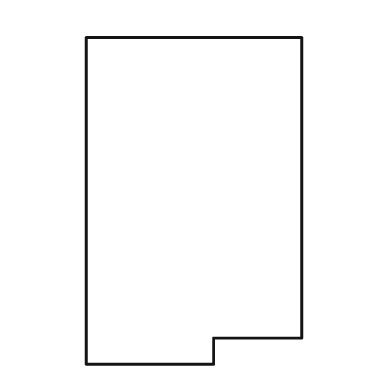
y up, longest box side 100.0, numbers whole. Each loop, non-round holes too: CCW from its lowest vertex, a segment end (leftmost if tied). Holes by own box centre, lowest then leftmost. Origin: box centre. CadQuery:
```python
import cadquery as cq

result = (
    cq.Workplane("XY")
    .moveTo(-33.0, -50.0)
    .lineTo(6.0, -50.0)
    .lineTo(6.0, -42.0)
    .lineTo(33.0, -42.0)
    .lineTo(33.0, 50.0)
    .lineTo(-33.0, 50.0)
    .close()
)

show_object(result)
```